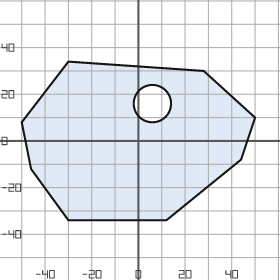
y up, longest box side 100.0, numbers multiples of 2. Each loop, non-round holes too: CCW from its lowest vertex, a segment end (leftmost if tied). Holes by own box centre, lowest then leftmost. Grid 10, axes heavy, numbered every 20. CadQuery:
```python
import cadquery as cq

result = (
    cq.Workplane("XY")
    .moveTo(-30.0, -34.0)
    .lineTo(12.0, -34.0)
    .lineTo(44.0, -8.0)
    .lineTo(50.0, 10.0)
    .lineTo(28.0, 30.0)
    .lineTo(-30.0, 34.0)
    .lineTo(-50.0, 8.0)
    .lineTo(-46.0, -12.0)
    .close()
    .moveTo(6.0, 16.0)
    .circle(8.0)
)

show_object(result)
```